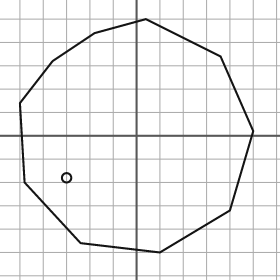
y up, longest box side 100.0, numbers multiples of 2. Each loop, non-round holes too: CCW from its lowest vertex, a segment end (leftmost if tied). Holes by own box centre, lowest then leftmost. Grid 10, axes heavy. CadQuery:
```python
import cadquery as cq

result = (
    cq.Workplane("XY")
    .moveTo(10.0, -50.0)
    .lineTo(40.0, -32.0)
    .lineTo(50.0, 2.0)
    .lineTo(36.0, 34.0)
    .lineTo(4.0, 50.0)
    .lineTo(-18.0, 44.0)
    .lineTo(-36.0, 32.0)
    .lineTo(-50.0, 14.0)
    .lineTo(-48.0, -20.0)
    .lineTo(-24.0, -46.0)
    .close()
    .moveTo(-30.0, -18.0)
    .circle(2.0)
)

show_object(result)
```